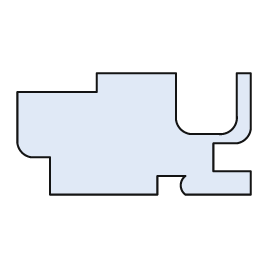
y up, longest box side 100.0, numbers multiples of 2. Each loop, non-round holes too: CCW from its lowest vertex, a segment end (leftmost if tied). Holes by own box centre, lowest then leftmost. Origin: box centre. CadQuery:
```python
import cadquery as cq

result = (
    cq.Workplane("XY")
    .moveTo(-36.0, -26.0)
    .lineTo(10.0, -26.0)
    .lineTo(10.0, -18.0)
    .lineTo(22.0, -18.0)
    .threePointArc((20.0, -22.0), (22.0, -26.0))
    .lineTo(50.0, -26.0)
    .lineTo(50.0, -16.0)
    .lineTo(34.0, -16.0)
    .lineTo(34.0, -4.0)
    .lineTo(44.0, -4.0)
    .threePointArc((48.0, -2.0), (50.0, 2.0))
    .lineTo(50.0, 26.0)
    .lineTo(44.0, 26.0)
    .lineTo(44.0, 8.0)
    .threePointArc((42.0, 2.0), (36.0, 0.0))
    .lineTo(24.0, 0.0)
    .threePointArc((20.0, 2.0), (18.0, 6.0))
    .lineTo(18.0, 26.0)
    .lineTo(-16.0, 26.0)
    .lineTo(-16.0, 18.0)
    .lineTo(-50.0, 18.0)
    .lineTo(-50.0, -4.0)
    .threePointArc((-48.0, -8.0), (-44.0, -10.0))
    .lineTo(-36.0, -10.0)
    .close()
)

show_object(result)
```